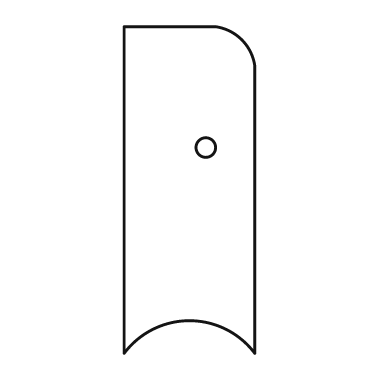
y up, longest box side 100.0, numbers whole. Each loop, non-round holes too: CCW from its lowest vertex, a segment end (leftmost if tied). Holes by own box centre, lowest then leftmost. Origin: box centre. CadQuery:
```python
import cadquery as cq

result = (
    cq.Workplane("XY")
    .moveTo(-20.0, -50.0)
    .threePointArc((0.0, -40.0), (20.0, -50.0))
    .lineTo(20.0, 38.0)
    .threePointArc((16.0, 46.0), (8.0, 50.0))
    .lineTo(-20.0, 50.0)
    .close()
    .moveTo(5.0, 13.0)
    .circle(3.0)
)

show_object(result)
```